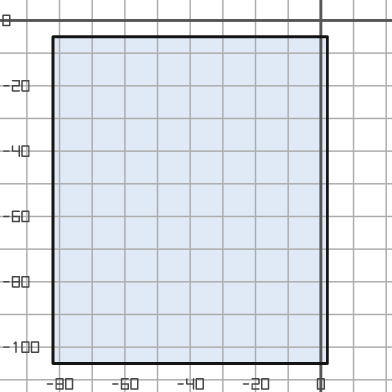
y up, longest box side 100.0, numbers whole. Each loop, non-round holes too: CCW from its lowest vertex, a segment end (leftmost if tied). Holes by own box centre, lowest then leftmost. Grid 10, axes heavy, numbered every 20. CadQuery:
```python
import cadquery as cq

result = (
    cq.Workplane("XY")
    .moveTo(-82.0, -105.0)
    .lineTo(2.0, -105.0)
    .lineTo(2.0, -5.0)
    .lineTo(-82.0, -5.0)
    .close()
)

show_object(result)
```